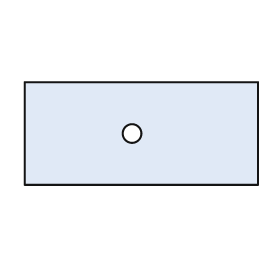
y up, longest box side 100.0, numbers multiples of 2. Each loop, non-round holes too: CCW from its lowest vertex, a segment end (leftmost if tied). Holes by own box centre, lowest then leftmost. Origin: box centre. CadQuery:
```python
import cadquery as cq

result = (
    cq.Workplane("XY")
    .moveTo(-50.0, -22.0)
    .lineTo(50.0, -22.0)
    .lineTo(50.0, 22.0)
    .lineTo(-50.0, 22.0)
    .close()
    .moveTo(-4.0, 0.0)
    .circle(4.0)
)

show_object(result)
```